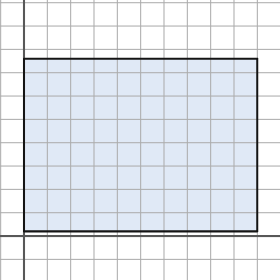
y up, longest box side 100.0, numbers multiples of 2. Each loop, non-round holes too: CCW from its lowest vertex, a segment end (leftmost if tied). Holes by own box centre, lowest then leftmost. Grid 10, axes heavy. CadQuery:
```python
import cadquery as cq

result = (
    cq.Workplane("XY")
    .moveTo(0.0, 2.0)
    .lineTo(100.0, 2.0)
    .lineTo(100.0, 76.0)
    .lineTo(0.0, 76.0)
    .close()
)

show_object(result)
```